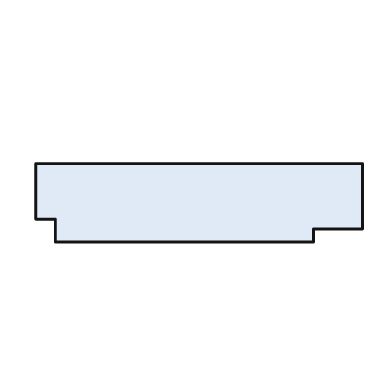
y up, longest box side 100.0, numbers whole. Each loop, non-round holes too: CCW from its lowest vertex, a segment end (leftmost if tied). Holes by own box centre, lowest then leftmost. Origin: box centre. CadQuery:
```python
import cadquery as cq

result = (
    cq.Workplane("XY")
    .moveTo(-44.0, -12.0)
    .lineTo(35.0, -12.0)
    .lineTo(35.0, -8.0)
    .lineTo(50.0, -8.0)
    .lineTo(50.0, 12.0)
    .lineTo(-50.0, 12.0)
    .lineTo(-50.0, -5.0)
    .lineTo(-44.0, -5.0)
    .close()
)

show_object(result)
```